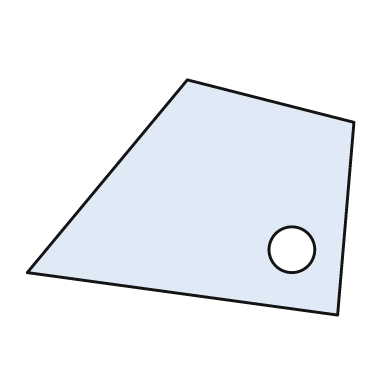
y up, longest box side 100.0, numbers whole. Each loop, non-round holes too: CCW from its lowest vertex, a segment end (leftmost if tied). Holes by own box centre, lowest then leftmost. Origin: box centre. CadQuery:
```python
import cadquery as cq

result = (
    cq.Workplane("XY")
    .moveTo(45.0, -36.0)
    .lineTo(50.0, 23.0)
    .lineTo(-1.0, 36.0)
    .lineTo(-50.0, -23.0)
    .close()
    .moveTo(31.0, -16.0)
    .circle(7.0)
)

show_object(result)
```